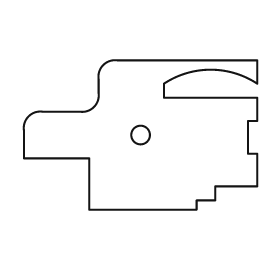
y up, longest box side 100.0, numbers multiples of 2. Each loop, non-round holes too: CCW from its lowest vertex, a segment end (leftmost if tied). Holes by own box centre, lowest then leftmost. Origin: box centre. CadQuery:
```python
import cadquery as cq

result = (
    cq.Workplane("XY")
    .moveTo(-22.0, -32.0)
    .lineTo(24.0, -32.0)
    .lineTo(24.0, -28.0)
    .lineTo(32.0, -28.0)
    .lineTo(32.0, -22.0)
    .lineTo(50.0, -22.0)
    .lineTo(50.0, -8.0)
    .lineTo(46.0, -8.0)
    .lineTo(46.0, 6.0)
    .lineTo(50.0, 6.0)
    .lineTo(50.0, 16.0)
    .lineTo(10.0, 16.0)
    .lineTo(10.0, 22.0)
    .threePointArc((30.0, 28.0), (50.0, 22.0))
    .lineTo(50.0, 32.0)
    .lineTo(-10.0, 32.0)
    .threePointArc((-16.0, 30.0), (-18.0, 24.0))
    .lineTo(-18.0, 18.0)
    .threePointArc((-20.0, 12.0), (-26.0, 10.0))
    .lineTo(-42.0, 10.0)
    .threePointArc((-48.0, 8.0), (-50.0, 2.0))
    .lineTo(-50.0, -10.0)
    .lineTo(-22.0, -10.0)
    .close()
    .moveTo(0.0, 0.0)
    .circle(4.0)
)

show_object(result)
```